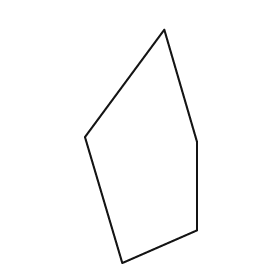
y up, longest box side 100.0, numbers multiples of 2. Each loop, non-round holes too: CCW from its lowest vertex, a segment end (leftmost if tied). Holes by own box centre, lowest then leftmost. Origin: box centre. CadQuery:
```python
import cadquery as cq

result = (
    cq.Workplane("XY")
    .moveTo(-8.0, -50.0)
    .lineTo(24.0, -36.0)
    .lineTo(24.0, 2.0)
    .lineTo(10.0, 50.0)
    .lineTo(-24.0, 4.0)
    .close()
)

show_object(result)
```